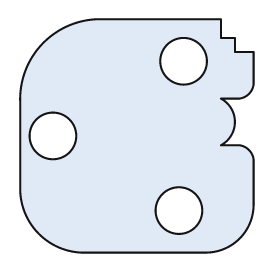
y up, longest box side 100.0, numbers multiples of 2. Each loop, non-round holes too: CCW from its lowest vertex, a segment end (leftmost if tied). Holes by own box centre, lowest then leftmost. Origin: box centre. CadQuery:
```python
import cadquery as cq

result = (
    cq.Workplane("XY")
    .moveTo(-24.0, -50.0)
    .lineTo(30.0, -50.0)
    .threePointArc((44.0, -44.0), (50.0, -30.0))
    .lineTo(50.0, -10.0)
    .threePointArc((48.0, -6.0), (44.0, -4.0))
    .lineTo(36.0, -4.0)
    .threePointArc((42.0, 6.0), (36.0, 16.0))
    .lineTo(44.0, 16.0)
    .threePointArc((48.0, 18.0), (50.0, 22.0))
    .lineTo(50.0, 36.0)
    .lineTo(42.0, 36.0)
    .lineTo(42.0, 42.0)
    .lineTo(36.0, 42.0)
    .lineTo(36.0, 50.0)
    .lineTo(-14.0, 50.0)
    .threePointArc((-40.0, 40.0), (-50.0, 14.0))
    .lineTo(-50.0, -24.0)
    .threePointArc((-42.0, -42.0), (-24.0, -50.0))
    .close()
    .moveTo(18.0, -32.0)
    .circle(10.0)
    .moveTo(-36.0, 0.0)
    .circle(10.0)
    .moveTo(20.0, 32.0)
    .circle(10.0)
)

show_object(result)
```